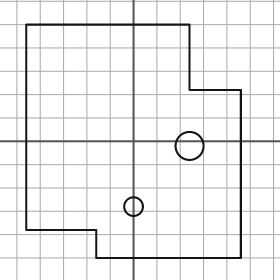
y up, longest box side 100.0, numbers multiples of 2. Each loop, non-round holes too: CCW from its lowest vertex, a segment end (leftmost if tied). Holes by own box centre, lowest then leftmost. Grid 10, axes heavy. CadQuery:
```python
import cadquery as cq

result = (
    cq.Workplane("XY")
    .moveTo(-16.0, -50.0)
    .lineTo(46.0, -50.0)
    .lineTo(46.0, 22.0)
    .lineTo(24.0, 22.0)
    .lineTo(24.0, 50.0)
    .lineTo(-46.0, 50.0)
    .lineTo(-46.0, -38.0)
    .lineTo(-16.0, -38.0)
    .close()
    .moveTo(0.0, -28.0)
    .circle(4.0)
    .moveTo(24.0, -2.0)
    .circle(6.0)
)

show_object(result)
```